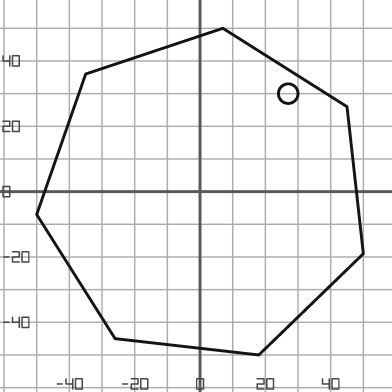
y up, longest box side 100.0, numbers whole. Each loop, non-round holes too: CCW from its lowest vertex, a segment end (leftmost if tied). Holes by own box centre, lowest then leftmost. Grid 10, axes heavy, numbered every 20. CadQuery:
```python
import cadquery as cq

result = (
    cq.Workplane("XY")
    .moveTo(18.0, -50.0)
    .lineTo(50.0, -19.0)
    .lineTo(45.0, 26.0)
    .lineTo(7.0, 50.0)
    .lineTo(-35.0, 36.0)
    .lineTo(-50.0, -7.0)
    .lineTo(-26.0, -45.0)
    .close()
    .moveTo(27.0, 30.0)
    .circle(3.0)
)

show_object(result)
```